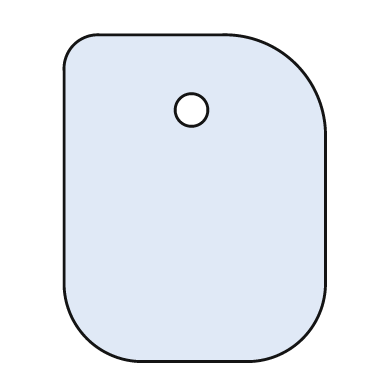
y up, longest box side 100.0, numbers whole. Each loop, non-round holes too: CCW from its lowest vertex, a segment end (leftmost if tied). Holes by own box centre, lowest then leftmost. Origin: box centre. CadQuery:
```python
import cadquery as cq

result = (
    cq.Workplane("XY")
    .moveTo(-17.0, -50.0)
    .lineTo(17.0, -50.0)
    .threePointArc((33.0, -43.0), (40.0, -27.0))
    .lineTo(40.0, 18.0)
    .threePointArc((31.0, 41.0), (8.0, 50.0))
    .lineTo(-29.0, 50.0)
    .threePointArc((-37.0, 47.0), (-40.0, 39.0))
    .lineTo(-40.0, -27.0)
    .threePointArc((-33.0, -43.0), (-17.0, -50.0))
    .close()
    .moveTo(-1.0, 27.0)
    .circle(5.0)
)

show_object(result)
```